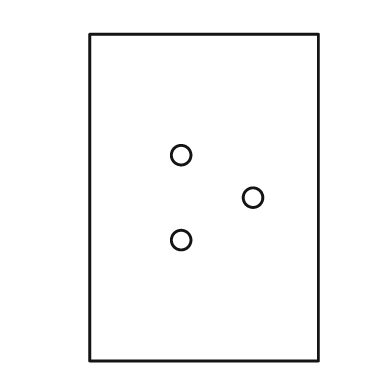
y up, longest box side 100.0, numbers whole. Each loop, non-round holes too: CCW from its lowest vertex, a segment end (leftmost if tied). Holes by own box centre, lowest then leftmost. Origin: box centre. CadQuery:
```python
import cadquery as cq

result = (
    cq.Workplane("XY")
    .moveTo(-35.0, -50.0)
    .lineTo(35.0, -50.0)
    .lineTo(35.0, 50.0)
    .lineTo(-35.0, 50.0)
    .close()
    .moveTo(-7.0, -13.0)
    .circle(3.0)
    .moveTo(15.0, 0.0)
    .circle(3.0)
    .moveTo(-7.0, 13.0)
    .circle(3.0)
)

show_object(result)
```